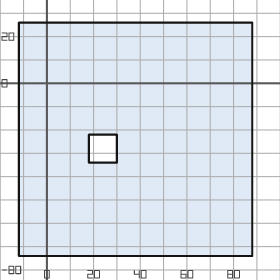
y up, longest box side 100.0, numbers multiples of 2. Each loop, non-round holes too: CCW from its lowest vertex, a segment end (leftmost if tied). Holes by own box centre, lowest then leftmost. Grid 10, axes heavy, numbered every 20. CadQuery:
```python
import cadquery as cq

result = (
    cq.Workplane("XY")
    .moveTo(-12.0, -74.0)
    .lineTo(88.0, -74.0)
    .lineTo(88.0, 26.0)
    .lineTo(-12.0, 26.0)
    .close()
    .moveTo(18.0, -34.0)
    .lineTo(30.0, -34.0)
    .lineTo(30.0, -22.0)
    .lineTo(18.0, -22.0)
    .close()
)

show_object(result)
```